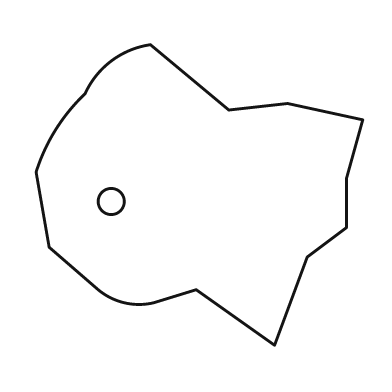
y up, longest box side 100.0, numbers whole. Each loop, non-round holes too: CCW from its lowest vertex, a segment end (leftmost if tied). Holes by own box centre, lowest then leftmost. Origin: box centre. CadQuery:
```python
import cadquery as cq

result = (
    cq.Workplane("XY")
    .moveTo(23.0, -46.0)
    .lineTo(33.0, -19.0)
    .lineTo(45.0, -10.0)
    .lineTo(45.0, 5.0)
    .lineTo(50.0, 23.0)
    .lineTo(27.0, 28.0)
    .lineTo(9.0, 26.0)
    .lineTo(-15.0, 46.0)
    .threePointArc((-27.0, 41.0), (-35.0, 31.0))
    .threePointArc((-44.0, 20.0), (-50.0, 7.0))
    .lineTo(-46.0, -16.0)
    .lineTo(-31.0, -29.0)
    .threePointArc((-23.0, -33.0), (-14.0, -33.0))
    .lineTo(-1.0, -29.0)
    .close()
    .moveTo(-27.0, -2.0)
    .circle(4.0)
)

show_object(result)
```